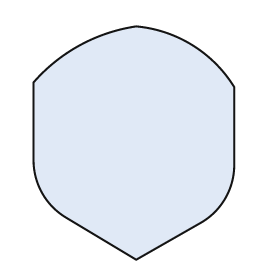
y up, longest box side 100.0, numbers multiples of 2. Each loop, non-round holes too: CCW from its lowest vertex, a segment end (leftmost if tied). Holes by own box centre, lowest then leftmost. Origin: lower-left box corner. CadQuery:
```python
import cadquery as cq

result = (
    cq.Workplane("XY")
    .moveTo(44.0, 0.0)
    .lineTo(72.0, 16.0)
    .threePointArc((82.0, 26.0), (86.0, 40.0))
    .lineTo(86.0, 74.0)
    .threePointArc((68.0, 92.0), (44.0, 100.0))
    .threePointArc((20.0, 92.0), (0.0, 76.0))
    .lineTo(0.0, 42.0)
    .threePointArc((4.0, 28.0), (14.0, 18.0))
    .close()
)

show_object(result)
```